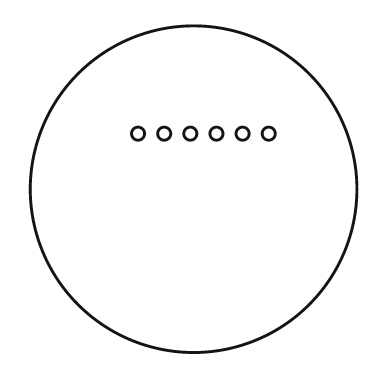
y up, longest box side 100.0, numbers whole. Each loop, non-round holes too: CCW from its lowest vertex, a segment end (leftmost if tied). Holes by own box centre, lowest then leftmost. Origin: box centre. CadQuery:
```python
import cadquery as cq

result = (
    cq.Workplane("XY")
    .moveTo(0.0, 0.0)
    .circle(50.0)
    .moveTo(-17.0, 17.0)
    .circle(2.0)
    .moveTo(-9.0, 17.0)
    .circle(2.0)
    .moveTo(-1.0, 17.0)
    .circle(2.0)
    .moveTo(7.0, 17.0)
    .circle(2.0)
    .moveTo(15.0, 17.0)
    .circle(2.0)
    .moveTo(23.0, 17.0)
    .circle(2.0)
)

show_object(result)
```